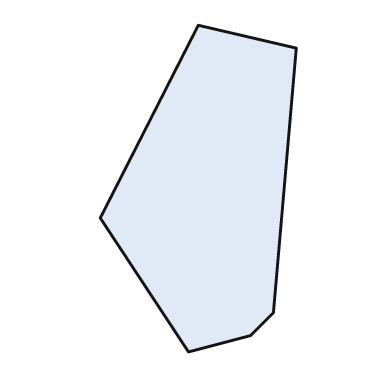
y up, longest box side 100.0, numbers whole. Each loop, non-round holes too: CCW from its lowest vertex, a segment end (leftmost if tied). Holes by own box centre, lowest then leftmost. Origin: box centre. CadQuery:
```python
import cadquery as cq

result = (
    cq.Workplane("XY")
    .moveTo(-3.0, -50.0)
    .lineTo(16.0, -45.0)
    .lineTo(23.0, -38.0)
    .lineTo(30.0, 43.0)
    .lineTo(0.0, 50.0)
    .lineTo(-30.0, -9.0)
    .close()
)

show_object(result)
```